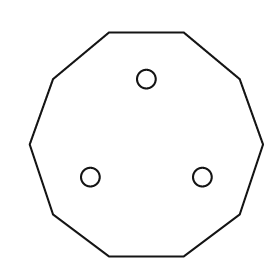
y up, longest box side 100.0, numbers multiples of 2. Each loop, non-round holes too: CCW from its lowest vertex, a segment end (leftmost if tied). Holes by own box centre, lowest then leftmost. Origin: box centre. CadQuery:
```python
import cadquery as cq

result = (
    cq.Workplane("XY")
    .moveTo(-16.0, -48.0)
    .lineTo(16.0, -48.0)
    .lineTo(40.0, -30.0)
    .lineTo(50.0, 0.0)
    .lineTo(40.0, 28.0)
    .lineTo(16.0, 48.0)
    .lineTo(-16.0, 48.0)
    .lineTo(-40.0, 28.0)
    .lineTo(-50.0, 0.0)
    .lineTo(-40.0, -30.0)
    .close()
    .moveTo(-24.0, -14.0)
    .circle(4.0)
    .moveTo(24.0, -14.0)
    .circle(4.0)
    .moveTo(0.0, 28.0)
    .circle(4.0)
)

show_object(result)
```